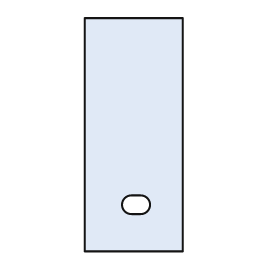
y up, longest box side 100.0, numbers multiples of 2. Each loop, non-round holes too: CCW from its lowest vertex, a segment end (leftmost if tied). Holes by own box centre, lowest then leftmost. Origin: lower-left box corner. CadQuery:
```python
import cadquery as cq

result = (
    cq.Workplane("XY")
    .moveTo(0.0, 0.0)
    .lineTo(42.0, 0.0)
    .lineTo(42.0, 100.0)
    .lineTo(0.0, 100.0)
    .close()
    .moveTo(20.0, 16.0)
    .lineTo(24.0, 16.0)
    .threePointArc((28.0, 20.0), (24.0, 24.0))
    .lineTo(20.0, 24.0)
    .threePointArc((16.0, 20.0), (20.0, 16.0))
    .close()
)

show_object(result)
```